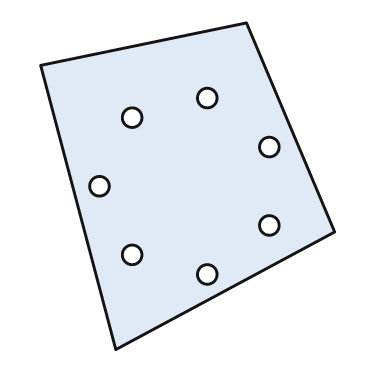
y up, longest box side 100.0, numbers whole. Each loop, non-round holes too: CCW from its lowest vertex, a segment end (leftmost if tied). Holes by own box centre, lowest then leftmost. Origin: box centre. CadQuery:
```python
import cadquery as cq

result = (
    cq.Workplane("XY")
    .moveTo(-22.0, -50.0)
    .lineTo(45.0, -14.0)
    .lineTo(18.0, 50.0)
    .lineTo(-45.0, 37.0)
    .close()
    .moveTo(6.0, -27.0)
    .circle(3.0)
    .moveTo(-17.0, -21.0)
    .circle(3.0)
    .moveTo(25.0, -12.0)
    .circle(3.0)
    .moveTo(-27.0, 0.0)
    .circle(3.0)
    .moveTo(25.0, 12.0)
    .circle(3.0)
    .moveTo(-17.0, 21.0)
    .circle(3.0)
    .moveTo(6.0, 27.0)
    .circle(3.0)
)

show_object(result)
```